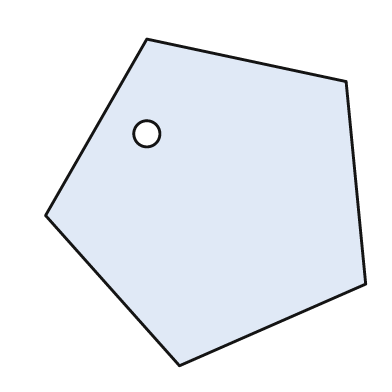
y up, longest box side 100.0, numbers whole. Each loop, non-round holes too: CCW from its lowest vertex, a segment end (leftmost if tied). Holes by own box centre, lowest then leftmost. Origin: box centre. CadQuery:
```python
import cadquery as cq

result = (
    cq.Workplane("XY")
    .moveTo(-8.0, -50.0)
    .lineTo(49.0, -25.0)
    .lineTo(43.0, 37.0)
    .lineTo(-18.0, 50.0)
    .lineTo(-49.0, -4.0)
    .close()
    .moveTo(-18.0, 21.0)
    .circle(4.0)
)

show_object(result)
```